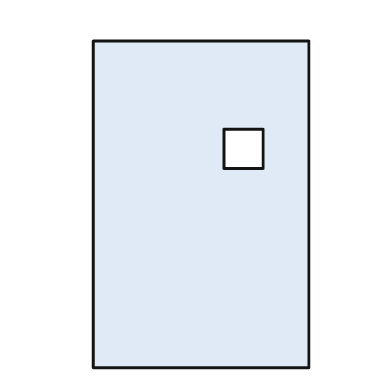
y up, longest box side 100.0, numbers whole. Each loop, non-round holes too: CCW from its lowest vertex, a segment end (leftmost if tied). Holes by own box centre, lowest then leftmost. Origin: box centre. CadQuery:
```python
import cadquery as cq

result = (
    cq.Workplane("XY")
    .moveTo(-33.0, -50.0)
    .lineTo(33.0, -50.0)
    .lineTo(33.0, 50.0)
    .lineTo(-33.0, 50.0)
    .close()
    .moveTo(7.0, 11.0)
    .lineTo(19.0, 11.0)
    .lineTo(19.0, 23.0)
    .lineTo(7.0, 23.0)
    .close()
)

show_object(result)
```